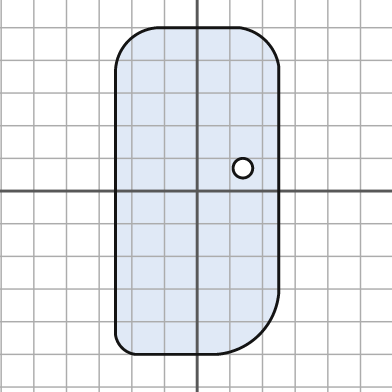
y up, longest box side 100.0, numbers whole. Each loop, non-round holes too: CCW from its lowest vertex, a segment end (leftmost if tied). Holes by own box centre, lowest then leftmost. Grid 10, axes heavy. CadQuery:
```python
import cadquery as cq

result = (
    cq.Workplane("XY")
    .moveTo(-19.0, -50.0)
    .lineTo(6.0, -50.0)
    .threePointArc((19.0, -44.0), (25.0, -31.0))
    .lineTo(25.0, 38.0)
    .threePointArc((21.0, 46.0), (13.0, 50.0))
    .lineTo(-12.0, 50.0)
    .threePointArc((-21.0, 46.0), (-25.0, 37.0))
    .lineTo(-25.0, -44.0)
    .threePointArc((-23.0, -48.0), (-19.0, -50.0))
    .close()
    .moveTo(14.0, 7.0)
    .circle(3.0)
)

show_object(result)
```